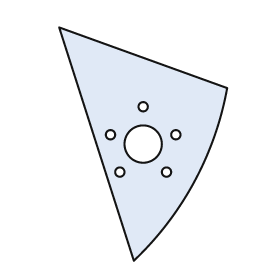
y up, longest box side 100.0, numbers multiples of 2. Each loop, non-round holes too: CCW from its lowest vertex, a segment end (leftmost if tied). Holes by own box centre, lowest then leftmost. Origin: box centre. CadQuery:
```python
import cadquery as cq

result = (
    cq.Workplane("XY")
    .moveTo(-4.0, -50.0)
    .threePointArc((22.0, -16.0), (36.0, 24.0))
    .lineTo(-36.0, 50.0)
    .close()
    .moveTo(-10.0, -12.0)
    .circle(2.0)
    .moveTo(10.0, -12.0)
    .circle(2.0)
    .moveTo(0.0, 0.0)
    .circle(8.0)
    .moveTo(-14.0, 4.0)
    .circle(2.0)
    .moveTo(14.0, 4.0)
    .circle(2.0)
    .moveTo(0.0, 16.0)
    .circle(2.0)
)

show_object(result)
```